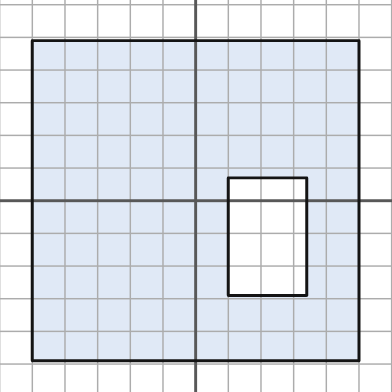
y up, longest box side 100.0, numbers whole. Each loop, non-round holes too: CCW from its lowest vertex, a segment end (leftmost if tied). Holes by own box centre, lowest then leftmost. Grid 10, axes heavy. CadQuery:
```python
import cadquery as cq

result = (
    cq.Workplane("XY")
    .moveTo(-50.0, -49.0)
    .lineTo(50.0, -49.0)
    .lineTo(50.0, 49.0)
    .lineTo(-50.0, 49.0)
    .close()
    .moveTo(10.0, -29.0)
    .lineTo(34.0, -29.0)
    .lineTo(34.0, 7.0)
    .lineTo(10.0, 7.0)
    .close()
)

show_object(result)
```